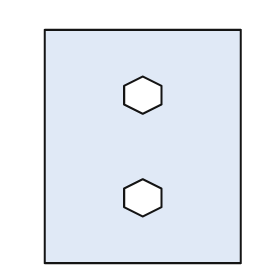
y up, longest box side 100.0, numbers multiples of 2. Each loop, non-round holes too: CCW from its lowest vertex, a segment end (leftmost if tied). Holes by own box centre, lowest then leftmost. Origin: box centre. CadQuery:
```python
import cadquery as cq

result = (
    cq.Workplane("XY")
    .moveTo(-42.0, -50.0)
    .lineTo(42.0, -50.0)
    .lineTo(42.0, 50.0)
    .lineTo(-42.0, 50.0)
    .close()
    .moveTo(0.0, -30.0)
    .lineTo(8.0, -26.0)
    .lineTo(8.0, -18.0)
    .lineTo(0.0, -14.0)
    .lineTo(-8.0, -18.0)
    .lineTo(-8.0, -26.0)
    .close()
    .moveTo(0.0, 14.0)
    .lineTo(8.0, 18.0)
    .lineTo(8.0, 26.0)
    .lineTo(0.0, 30.0)
    .lineTo(-8.0, 26.0)
    .lineTo(-8.0, 18.0)
    .close()
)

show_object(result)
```